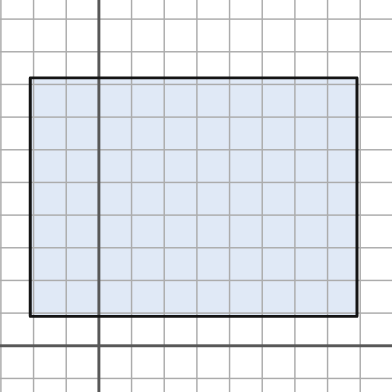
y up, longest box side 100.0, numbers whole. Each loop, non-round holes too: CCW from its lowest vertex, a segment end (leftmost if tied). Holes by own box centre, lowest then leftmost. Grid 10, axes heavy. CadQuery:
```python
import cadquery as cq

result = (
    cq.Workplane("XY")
    .moveTo(-21.0, 9.0)
    .lineTo(79.0, 9.0)
    .lineTo(79.0, 82.0)
    .lineTo(-21.0, 82.0)
    .close()
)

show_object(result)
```